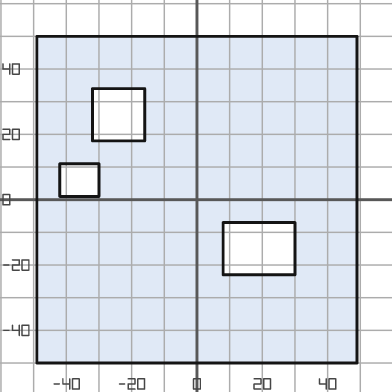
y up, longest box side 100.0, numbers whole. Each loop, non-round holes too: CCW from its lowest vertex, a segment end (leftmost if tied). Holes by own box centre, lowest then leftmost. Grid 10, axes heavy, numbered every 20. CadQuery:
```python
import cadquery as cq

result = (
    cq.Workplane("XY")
    .moveTo(-49.0, -50.0)
    .lineTo(49.0, -50.0)
    .lineTo(49.0, 50.0)
    .lineTo(-49.0, 50.0)
    .close()
    .moveTo(8.0, -23.0)
    .lineTo(30.0, -23.0)
    .lineTo(30.0, -7.0)
    .lineTo(8.0, -7.0)
    .close()
    .moveTo(-42.0, 1.0)
    .lineTo(-30.0, 1.0)
    .lineTo(-30.0, 11.0)
    .lineTo(-42.0, 11.0)
    .close()
    .moveTo(-32.0, 18.0)
    .lineTo(-16.0, 18.0)
    .lineTo(-16.0, 34.0)
    .lineTo(-32.0, 34.0)
    .close()
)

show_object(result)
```